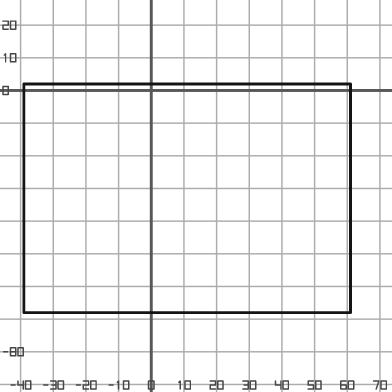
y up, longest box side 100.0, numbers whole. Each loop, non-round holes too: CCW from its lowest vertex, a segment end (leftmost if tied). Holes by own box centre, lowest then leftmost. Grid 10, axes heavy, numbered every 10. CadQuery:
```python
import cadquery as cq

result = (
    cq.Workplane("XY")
    .moveTo(-39.0, -68.0)
    .lineTo(61.0, -68.0)
    .lineTo(61.0, 2.0)
    .lineTo(-39.0, 2.0)
    .close()
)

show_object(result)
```